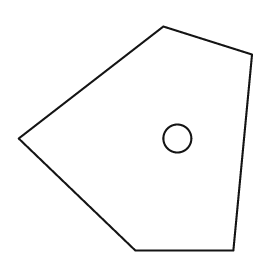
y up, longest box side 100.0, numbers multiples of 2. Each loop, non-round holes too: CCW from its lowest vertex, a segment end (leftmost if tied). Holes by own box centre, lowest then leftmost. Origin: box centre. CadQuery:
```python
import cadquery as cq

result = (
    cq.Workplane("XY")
    .moveTo(0.0, -48.0)
    .lineTo(42.0, -48.0)
    .lineTo(50.0, 36.0)
    .lineTo(12.0, 48.0)
    .lineTo(-50.0, 0.0)
    .close()
    .moveTo(18.0, 0.0)
    .circle(6.0)
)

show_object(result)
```